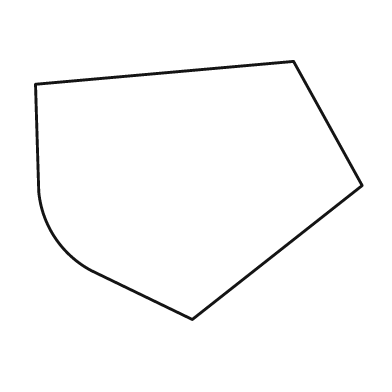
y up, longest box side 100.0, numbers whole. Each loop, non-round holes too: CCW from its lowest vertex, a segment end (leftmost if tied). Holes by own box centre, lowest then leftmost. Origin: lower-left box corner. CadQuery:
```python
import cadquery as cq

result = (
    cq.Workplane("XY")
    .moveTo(48.0, 0.0)
    .lineTo(100.0, 41.0)
    .lineTo(79.0, 79.0)
    .lineTo(0.0, 72.0)
    .lineTo(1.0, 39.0)
    .threePointArc((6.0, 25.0), (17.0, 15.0))
    .close()
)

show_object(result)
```